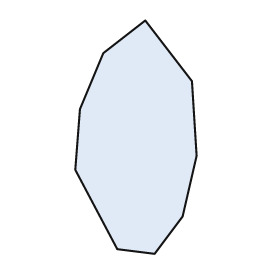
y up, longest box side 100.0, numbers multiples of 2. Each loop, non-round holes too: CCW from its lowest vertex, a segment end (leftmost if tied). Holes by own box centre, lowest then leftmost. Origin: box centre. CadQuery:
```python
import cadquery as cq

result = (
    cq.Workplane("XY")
    .moveTo(8.0, -50.0)
    .lineTo(20.0, -34.0)
    .lineTo(26.0, -8.0)
    .lineTo(24.0, 24.0)
    .lineTo(4.0, 50.0)
    .lineTo(-14.0, 36.0)
    .lineTo(-24.0, 12.0)
    .lineTo(-26.0, -14.0)
    .lineTo(-8.0, -48.0)
    .close()
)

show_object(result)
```